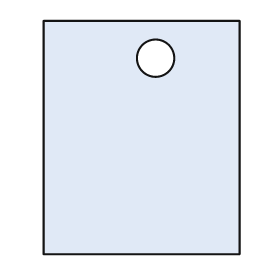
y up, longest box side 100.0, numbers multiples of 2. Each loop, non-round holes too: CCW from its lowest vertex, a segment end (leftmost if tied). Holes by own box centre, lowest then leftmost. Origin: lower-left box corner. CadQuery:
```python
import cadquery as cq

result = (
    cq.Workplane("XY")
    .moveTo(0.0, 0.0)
    .lineTo(84.0, 0.0)
    .lineTo(84.0, 100.0)
    .lineTo(0.0, 100.0)
    .close()
    .moveTo(48.0, 84.0)
    .circle(8.0)
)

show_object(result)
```